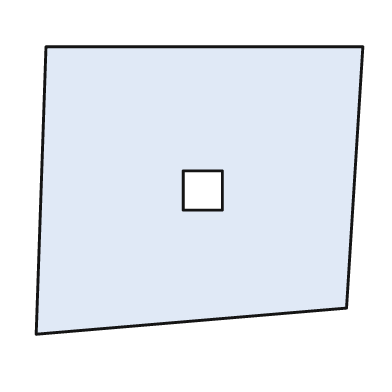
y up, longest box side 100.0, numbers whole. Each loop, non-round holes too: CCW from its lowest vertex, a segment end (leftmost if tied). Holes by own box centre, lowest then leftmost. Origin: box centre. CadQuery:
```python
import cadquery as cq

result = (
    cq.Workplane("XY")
    .moveTo(-50.0, -44.0)
    .lineTo(45.0, -36.0)
    .lineTo(50.0, 44.0)
    .lineTo(-47.0, 44.0)
    .close()
    .moveTo(-5.0, -6.0)
    .lineTo(7.0, -6.0)
    .lineTo(7.0, 6.0)
    .lineTo(-5.0, 6.0)
    .close()
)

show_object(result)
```